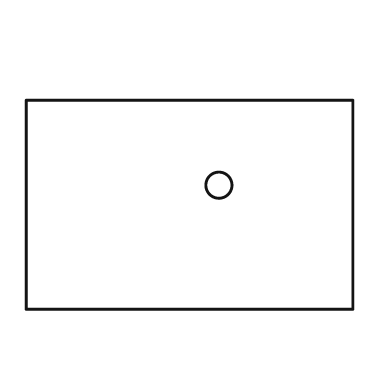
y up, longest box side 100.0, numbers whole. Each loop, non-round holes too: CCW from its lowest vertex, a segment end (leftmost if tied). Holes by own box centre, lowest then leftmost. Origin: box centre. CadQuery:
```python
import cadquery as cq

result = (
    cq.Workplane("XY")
    .moveTo(-50.0, -32.0)
    .lineTo(50.0, -32.0)
    .lineTo(50.0, 32.0)
    .lineTo(-50.0, 32.0)
    .close()
    .moveTo(9.0, 6.0)
    .circle(4.0)
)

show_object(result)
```